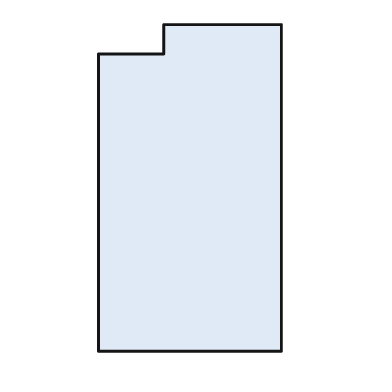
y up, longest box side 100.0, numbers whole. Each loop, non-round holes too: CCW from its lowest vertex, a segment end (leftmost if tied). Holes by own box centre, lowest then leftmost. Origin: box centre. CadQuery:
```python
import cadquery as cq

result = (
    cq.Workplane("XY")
    .moveTo(-28.0, -50.0)
    .lineTo(28.0, -50.0)
    .lineTo(28.0, 50.0)
    .lineTo(-8.0, 50.0)
    .lineTo(-8.0, 41.0)
    .lineTo(-28.0, 41.0)
    .close()
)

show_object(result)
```